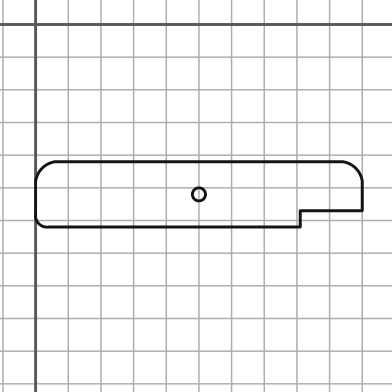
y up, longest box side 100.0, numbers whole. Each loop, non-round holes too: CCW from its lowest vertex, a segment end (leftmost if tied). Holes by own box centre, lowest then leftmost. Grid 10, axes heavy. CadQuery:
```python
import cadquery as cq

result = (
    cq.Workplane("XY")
    .moveTo(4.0, -62.0)
    .lineTo(81.0, -62.0)
    .lineTo(81.0, -57.0)
    .lineTo(100.0, -57.0)
    .lineTo(100.0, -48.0)
    .threePointArc((98.0, -44.0), (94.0, -42.0))
    .lineTo(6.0, -42.0)
    .threePointArc((2.0, -44.0), (0.0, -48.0))
    .lineTo(0.0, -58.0)
    .threePointArc((1.0, -61.0), (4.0, -62.0))
    .close()
    .moveTo(50.0, -52.0)
    .circle(2.0)
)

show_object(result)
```